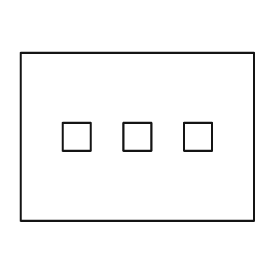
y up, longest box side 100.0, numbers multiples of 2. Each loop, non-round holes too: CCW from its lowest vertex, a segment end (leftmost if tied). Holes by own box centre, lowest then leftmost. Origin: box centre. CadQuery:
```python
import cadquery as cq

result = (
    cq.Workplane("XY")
    .moveTo(-50.0, -36.0)
    .lineTo(50.0, -36.0)
    .lineTo(50.0, 36.0)
    .lineTo(-50.0, 36.0)
    .close()
    .moveTo(-32.0, -6.0)
    .lineTo(-20.0, -6.0)
    .lineTo(-20.0, 6.0)
    .lineTo(-32.0, 6.0)
    .close()
    .moveTo(-6.0, -6.0)
    .lineTo(6.0, -6.0)
    .lineTo(6.0, 6.0)
    .lineTo(-6.0, 6.0)
    .close()
    .moveTo(20.0, -6.0)
    .lineTo(32.0, -6.0)
    .lineTo(32.0, 6.0)
    .lineTo(20.0, 6.0)
    .close()
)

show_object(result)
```